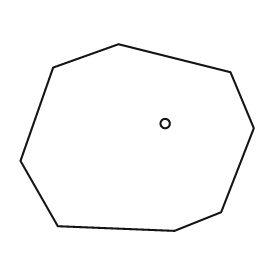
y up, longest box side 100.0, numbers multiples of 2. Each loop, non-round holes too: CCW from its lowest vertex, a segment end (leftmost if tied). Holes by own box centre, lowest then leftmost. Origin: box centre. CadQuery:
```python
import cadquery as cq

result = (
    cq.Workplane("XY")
    .moveTo(16.0, -40.0)
    .lineTo(36.0, -32.0)
    .lineTo(50.0, 4.0)
    .lineTo(40.0, 28.0)
    .lineTo(-8.0, 40.0)
    .lineTo(-36.0, 30.0)
    .lineTo(-50.0, -10.0)
    .lineTo(-34.0, -38.0)
    .close()
    .moveTo(12.0, 6.0)
    .circle(2.0)
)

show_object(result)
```